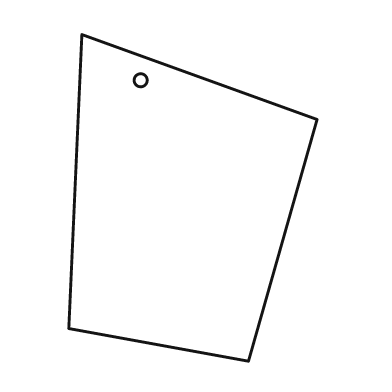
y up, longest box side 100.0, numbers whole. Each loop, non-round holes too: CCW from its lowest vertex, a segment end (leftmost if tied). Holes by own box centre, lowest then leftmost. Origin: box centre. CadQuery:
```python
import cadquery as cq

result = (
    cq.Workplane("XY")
    .moveTo(17.0, -50.0)
    .lineTo(38.0, 24.0)
    .lineTo(-34.0, 50.0)
    .lineTo(-38.0, -40.0)
    .close()
    .moveTo(-16.0, 36.0)
    .circle(2.0)
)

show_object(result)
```